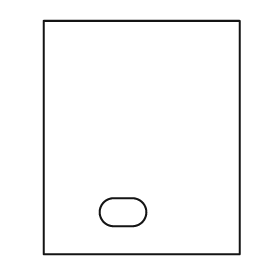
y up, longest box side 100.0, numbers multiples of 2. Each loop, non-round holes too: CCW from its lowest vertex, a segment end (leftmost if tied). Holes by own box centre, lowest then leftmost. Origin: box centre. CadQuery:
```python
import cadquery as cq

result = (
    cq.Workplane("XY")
    .moveTo(-42.0, -50.0)
    .lineTo(42.0, -50.0)
    .lineTo(42.0, 50.0)
    .lineTo(-42.0, 50.0)
    .close()
    .moveTo(-12.0, -38.0)
    .lineTo(-4.0, -38.0)
    .threePointArc((2.0, -32.0), (-4.0, -26.0))
    .lineTo(-12.0, -26.0)
    .threePointArc((-18.0, -32.0), (-12.0, -38.0))
    .close()
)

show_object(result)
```